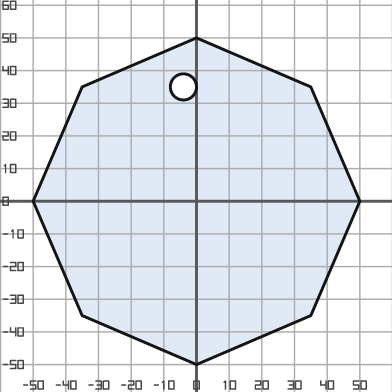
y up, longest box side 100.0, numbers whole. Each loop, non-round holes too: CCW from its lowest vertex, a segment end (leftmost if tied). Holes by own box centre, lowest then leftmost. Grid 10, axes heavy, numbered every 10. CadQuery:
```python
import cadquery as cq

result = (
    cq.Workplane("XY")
    .moveTo(0.0, -50.0)
    .lineTo(35.0, -35.0)
    .lineTo(50.0, 0.0)
    .lineTo(35.0, 35.0)
    .lineTo(0.0, 50.0)
    .lineTo(-35.0, 35.0)
    .lineTo(-50.0, 0.0)
    .lineTo(-35.0, -35.0)
    .close()
    .moveTo(-4.0, 35.0)
    .circle(4.0)
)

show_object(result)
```